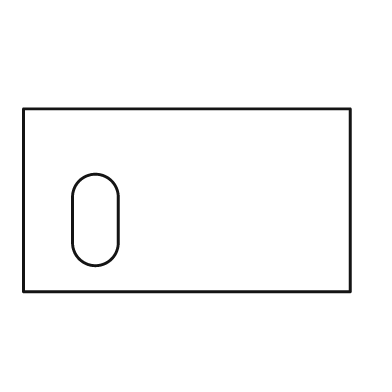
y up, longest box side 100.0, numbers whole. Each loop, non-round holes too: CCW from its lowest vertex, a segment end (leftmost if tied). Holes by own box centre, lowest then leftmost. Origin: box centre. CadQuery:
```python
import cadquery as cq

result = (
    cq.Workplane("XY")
    .moveTo(-50.0, -28.0)
    .lineTo(50.0, -28.0)
    .lineTo(50.0, 28.0)
    .lineTo(-50.0, 28.0)
    .close()
    .moveTo(-35.0, -13.0)
    .threePointArc((-28.0, -20.0), (-21.0, -13.0))
    .lineTo(-21.0, 1.0)
    .threePointArc((-28.0, 8.0), (-35.0, 1.0))
    .close()
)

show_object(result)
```